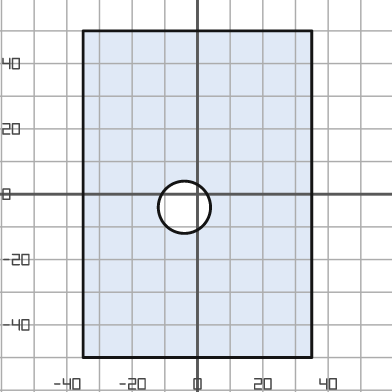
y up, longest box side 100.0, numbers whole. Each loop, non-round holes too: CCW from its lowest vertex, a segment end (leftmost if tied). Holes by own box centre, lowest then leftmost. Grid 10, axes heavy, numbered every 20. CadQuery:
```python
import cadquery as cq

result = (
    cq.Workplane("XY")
    .moveTo(-35.0, -50.0)
    .lineTo(35.0, -50.0)
    .lineTo(35.0, 50.0)
    .lineTo(-35.0, 50.0)
    .close()
    .moveTo(-4.0, -4.0)
    .circle(8.0)
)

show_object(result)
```